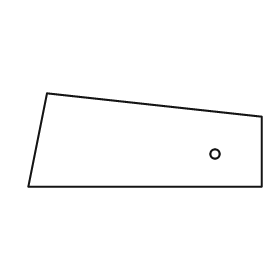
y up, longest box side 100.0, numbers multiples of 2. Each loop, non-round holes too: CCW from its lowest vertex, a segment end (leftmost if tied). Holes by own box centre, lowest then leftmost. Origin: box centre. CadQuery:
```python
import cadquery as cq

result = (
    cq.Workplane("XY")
    .moveTo(-50.0, -20.0)
    .lineTo(50.0, -20.0)
    .lineTo(50.0, 10.0)
    .lineTo(-42.0, 20.0)
    .close()
    .moveTo(30.0, -6.0)
    .circle(2.0)
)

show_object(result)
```